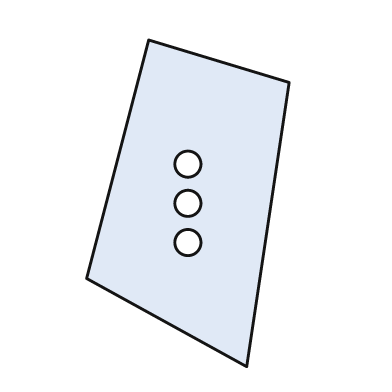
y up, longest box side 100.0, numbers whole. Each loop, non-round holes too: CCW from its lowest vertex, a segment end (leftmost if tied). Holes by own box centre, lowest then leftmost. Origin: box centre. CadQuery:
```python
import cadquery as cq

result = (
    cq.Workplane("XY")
    .moveTo(18.0, -50.0)
    .lineTo(31.0, 37.0)
    .lineTo(-12.0, 50.0)
    .lineTo(-31.0, -23.0)
    .close()
    .moveTo(0.0, -12.0)
    .circle(4.0)
    .moveTo(0.0, 0.0)
    .circle(4.0)
    .moveTo(0.0, 12.0)
    .circle(4.0)
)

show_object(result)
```